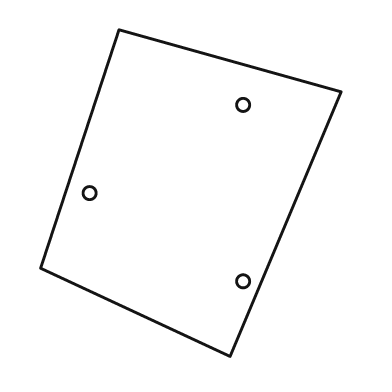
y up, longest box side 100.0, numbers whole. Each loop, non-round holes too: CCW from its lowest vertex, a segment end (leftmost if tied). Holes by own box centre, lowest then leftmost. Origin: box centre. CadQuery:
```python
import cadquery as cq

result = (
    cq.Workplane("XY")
    .moveTo(12.0, -50.0)
    .lineTo(46.0, 31.0)
    .lineTo(-22.0, 50.0)
    .lineTo(-46.0, -23.0)
    .close()
    .moveTo(16.0, -27.0)
    .circle(2.0)
    .moveTo(-31.0, 0.0)
    .circle(2.0)
    .moveTo(16.0, 27.0)
    .circle(2.0)
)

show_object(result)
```